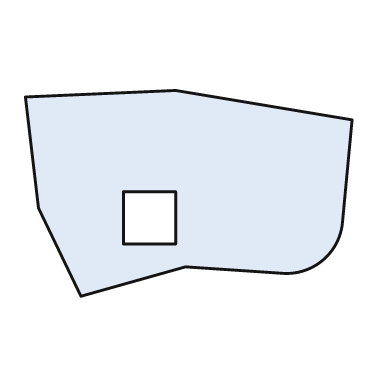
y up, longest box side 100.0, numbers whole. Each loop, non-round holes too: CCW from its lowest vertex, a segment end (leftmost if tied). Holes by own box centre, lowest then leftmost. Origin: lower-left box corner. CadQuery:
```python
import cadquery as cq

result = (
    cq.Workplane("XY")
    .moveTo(17.0, 0.0)
    .lineTo(49.0, 9.0)
    .lineTo(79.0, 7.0)
    .threePointArc((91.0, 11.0), (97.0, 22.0))
    .lineTo(100.0, 54.0)
    .lineTo(46.0, 63.0)
    .lineTo(0.0, 61.0)
    .lineTo(4.0, 27.0)
    .close()
    .moveTo(30.0, 16.0)
    .lineTo(46.0, 16.0)
    .lineTo(46.0, 32.0)
    .lineTo(30.0, 32.0)
    .close()
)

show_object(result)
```